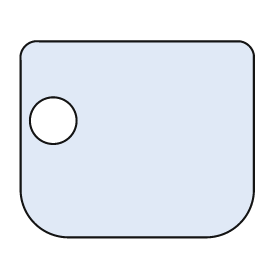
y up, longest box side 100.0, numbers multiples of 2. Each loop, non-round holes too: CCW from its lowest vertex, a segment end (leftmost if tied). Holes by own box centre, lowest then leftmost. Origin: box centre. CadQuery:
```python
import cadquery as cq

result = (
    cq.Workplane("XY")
    .moveTo(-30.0, -42.0)
    .lineTo(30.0, -42.0)
    .threePointArc((44.0, -36.0), (50.0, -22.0))
    .lineTo(50.0, 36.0)
    .threePointArc((48.0, 40.0), (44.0, 42.0))
    .lineTo(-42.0, 42.0)
    .threePointArc((-48.0, 40.0), (-50.0, 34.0))
    .lineTo(-50.0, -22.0)
    .threePointArc((-44.0, -36.0), (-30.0, -42.0))
    .close()
    .moveTo(-36.0, 8.0)
    .circle(10.0)
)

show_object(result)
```